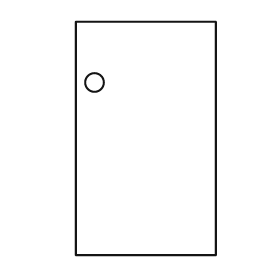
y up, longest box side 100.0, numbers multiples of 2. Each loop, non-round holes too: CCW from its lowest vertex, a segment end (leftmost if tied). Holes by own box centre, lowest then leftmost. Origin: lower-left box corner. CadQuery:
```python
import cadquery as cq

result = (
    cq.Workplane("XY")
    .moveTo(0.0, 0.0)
    .lineTo(60.0, 0.0)
    .lineTo(60.0, 100.0)
    .lineTo(0.0, 100.0)
    .close()
    .moveTo(8.0, 74.0)
    .circle(4.0)
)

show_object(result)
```